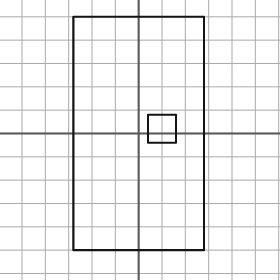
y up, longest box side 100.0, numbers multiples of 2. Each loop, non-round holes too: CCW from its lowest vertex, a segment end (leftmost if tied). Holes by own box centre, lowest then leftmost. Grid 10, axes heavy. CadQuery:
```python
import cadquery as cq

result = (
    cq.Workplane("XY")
    .moveTo(-28.0, -50.0)
    .lineTo(28.0, -50.0)
    .lineTo(28.0, 50.0)
    .lineTo(-28.0, 50.0)
    .close()
    .moveTo(4.0, -4.0)
    .lineTo(16.0, -4.0)
    .lineTo(16.0, 8.0)
    .lineTo(4.0, 8.0)
    .close()
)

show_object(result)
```